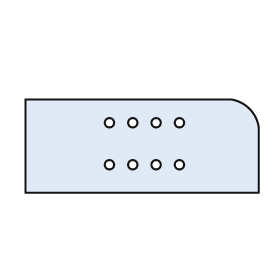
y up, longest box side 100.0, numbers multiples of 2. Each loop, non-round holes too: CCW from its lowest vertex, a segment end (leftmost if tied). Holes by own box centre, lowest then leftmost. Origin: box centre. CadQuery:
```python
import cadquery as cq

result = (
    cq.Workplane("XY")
    .moveTo(-50.0, -20.0)
    .lineTo(50.0, -20.0)
    .lineTo(50.0, 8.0)
    .threePointArc((46.0, 16.0), (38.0, 20.0))
    .lineTo(-50.0, 20.0)
    .close()
    .moveTo(-14.0, -8.0)
    .circle(2.0)
    .moveTo(-4.0, -8.0)
    .circle(2.0)
    .moveTo(6.0, -8.0)
    .circle(2.0)
    .moveTo(16.0, -8.0)
    .circle(2.0)
    .moveTo(-14.0, 10.0)
    .circle(2.0)
    .moveTo(-4.0, 10.0)
    .circle(2.0)
    .moveTo(6.0, 10.0)
    .circle(2.0)
    .moveTo(16.0, 10.0)
    .circle(2.0)
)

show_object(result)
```